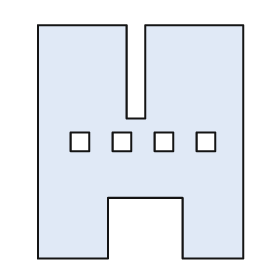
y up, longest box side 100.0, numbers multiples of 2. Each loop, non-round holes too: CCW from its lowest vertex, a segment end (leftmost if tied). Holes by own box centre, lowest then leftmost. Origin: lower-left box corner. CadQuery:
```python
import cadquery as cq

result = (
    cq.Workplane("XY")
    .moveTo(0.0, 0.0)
    .lineTo(30.0, 0.0)
    .lineTo(30.0, 26.0)
    .lineTo(62.0, 26.0)
    .lineTo(62.0, 0.0)
    .lineTo(88.0, 0.0)
    .lineTo(88.0, 100.0)
    .lineTo(46.0, 100.0)
    .lineTo(46.0, 60.0)
    .lineTo(38.0, 60.0)
    .lineTo(38.0, 100.0)
    .lineTo(0.0, 100.0)
    .close()
    .moveTo(14.0, 46.0)
    .lineTo(22.0, 46.0)
    .lineTo(22.0, 54.0)
    .lineTo(14.0, 54.0)
    .close()
    .moveTo(32.0, 46.0)
    .lineTo(40.0, 46.0)
    .lineTo(40.0, 54.0)
    .lineTo(32.0, 54.0)
    .close()
    .moveTo(50.0, 46.0)
    .lineTo(58.0, 46.0)
    .lineTo(58.0, 54.0)
    .lineTo(50.0, 54.0)
    .close()
    .moveTo(68.0, 46.0)
    .lineTo(76.0, 46.0)
    .lineTo(76.0, 54.0)
    .lineTo(68.0, 54.0)
    .close()
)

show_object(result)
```